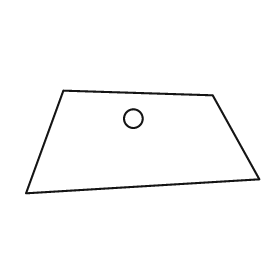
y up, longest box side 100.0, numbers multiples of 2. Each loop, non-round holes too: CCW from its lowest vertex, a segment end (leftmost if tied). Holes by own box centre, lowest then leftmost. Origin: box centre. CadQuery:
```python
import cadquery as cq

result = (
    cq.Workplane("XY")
    .moveTo(-50.0, -22.0)
    .lineTo(50.0, -16.0)
    .lineTo(30.0, 20.0)
    .lineTo(-34.0, 22.0)
    .close()
    .moveTo(-4.0, 10.0)
    .circle(4.0)
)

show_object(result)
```